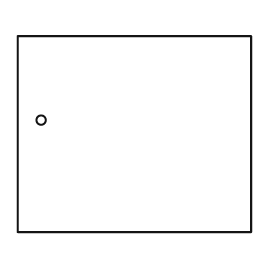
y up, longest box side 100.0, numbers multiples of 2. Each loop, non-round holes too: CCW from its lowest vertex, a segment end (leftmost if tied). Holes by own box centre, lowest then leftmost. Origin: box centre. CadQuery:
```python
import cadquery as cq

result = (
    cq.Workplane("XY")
    .moveTo(-50.0, -42.0)
    .lineTo(50.0, -42.0)
    .lineTo(50.0, 42.0)
    .lineTo(-50.0, 42.0)
    .close()
    .moveTo(-40.0, 6.0)
    .circle(2.0)
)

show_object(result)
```